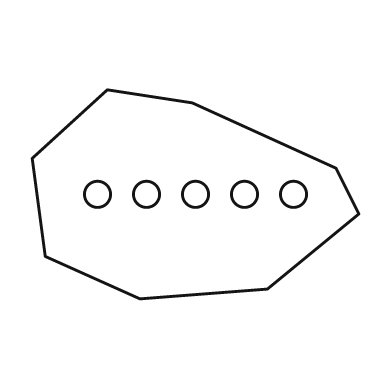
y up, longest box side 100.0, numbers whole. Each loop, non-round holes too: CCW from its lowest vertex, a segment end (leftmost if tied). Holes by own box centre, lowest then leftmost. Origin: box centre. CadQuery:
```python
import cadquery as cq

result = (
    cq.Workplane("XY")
    .moveTo(-17.0, -32.0)
    .lineTo(22.0, -29.0)
    .lineTo(50.0, -6.0)
    .lineTo(43.0, 8.0)
    .lineTo(-1.0, 28.0)
    .lineTo(-27.0, 32.0)
    .lineTo(-50.0, 11.0)
    .lineTo(-46.0, -19.0)
    .close()
    .moveTo(-30.0, 0.0)
    .circle(4.0)
    .moveTo(-15.0, 0.0)
    .circle(4.0)
    .moveTo(0.0, 0.0)
    .circle(4.0)
    .moveTo(15.0, 0.0)
    .circle(4.0)
    .moveTo(30.0, 0.0)
    .circle(4.0)
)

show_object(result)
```